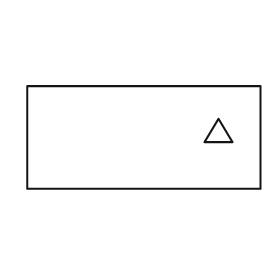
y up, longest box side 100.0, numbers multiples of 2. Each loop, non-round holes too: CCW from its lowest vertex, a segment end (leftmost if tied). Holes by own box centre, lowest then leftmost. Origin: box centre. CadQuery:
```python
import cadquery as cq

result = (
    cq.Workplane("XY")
    .moveTo(-50.0, -22.0)
    .lineTo(50.0, -22.0)
    .lineTo(50.0, 22.0)
    .lineTo(-50.0, 22.0)
    .close()
    .moveTo(26.0, -2.0)
    .lineTo(38.0, -2.0)
    .lineTo(32.0, 8.0)
    .close()
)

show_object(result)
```